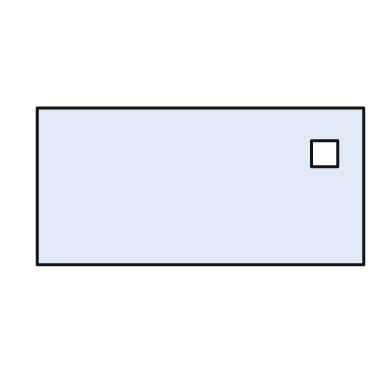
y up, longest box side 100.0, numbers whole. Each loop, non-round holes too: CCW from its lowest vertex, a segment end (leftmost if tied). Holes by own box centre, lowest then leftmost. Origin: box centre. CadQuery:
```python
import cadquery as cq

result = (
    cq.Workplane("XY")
    .moveTo(-50.0, -24.0)
    .lineTo(50.0, -24.0)
    .lineTo(50.0, 24.0)
    .lineTo(-50.0, 24.0)
    .close()
    .moveTo(34.0, 6.0)
    .lineTo(42.0, 6.0)
    .lineTo(42.0, 14.0)
    .lineTo(34.0, 14.0)
    .close()
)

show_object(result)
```